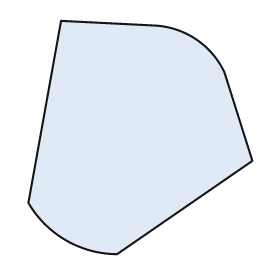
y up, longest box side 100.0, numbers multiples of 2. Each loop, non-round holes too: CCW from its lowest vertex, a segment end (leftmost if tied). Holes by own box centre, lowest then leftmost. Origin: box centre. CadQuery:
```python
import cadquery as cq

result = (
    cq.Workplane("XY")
    .moveTo(-10.0, -50.0)
    .lineTo(48.0, -10.0)
    .lineTo(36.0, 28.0)
    .threePointArc((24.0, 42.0), (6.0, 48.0))
    .lineTo(-34.0, 50.0)
    .lineTo(-48.0, -28.0)
    .threePointArc((-32.0, -44.0), (-10.0, -50.0))
    .close()
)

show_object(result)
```